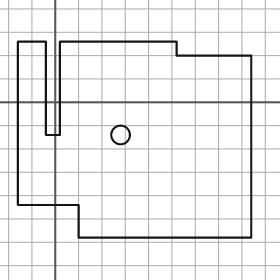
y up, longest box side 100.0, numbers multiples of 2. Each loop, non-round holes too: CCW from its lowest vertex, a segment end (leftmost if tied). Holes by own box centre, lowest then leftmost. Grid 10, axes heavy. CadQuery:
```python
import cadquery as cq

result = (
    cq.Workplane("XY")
    .moveTo(10.0, -58.0)
    .lineTo(84.0, -58.0)
    .lineTo(84.0, 20.0)
    .lineTo(52.0, 20.0)
    .lineTo(52.0, 26.0)
    .lineTo(2.0, 26.0)
    .lineTo(2.0, -14.0)
    .lineTo(-4.0, -14.0)
    .lineTo(-4.0, 26.0)
    .lineTo(-16.0, 26.0)
    .lineTo(-16.0, -44.0)
    .lineTo(10.0, -44.0)
    .close()
    .moveTo(28.0, -14.0)
    .circle(4.0)
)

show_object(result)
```